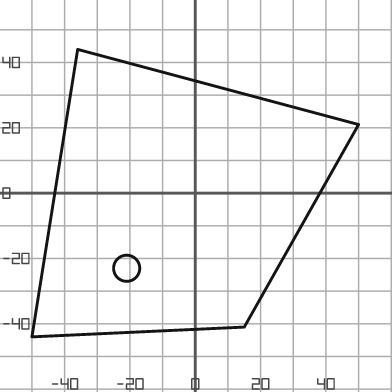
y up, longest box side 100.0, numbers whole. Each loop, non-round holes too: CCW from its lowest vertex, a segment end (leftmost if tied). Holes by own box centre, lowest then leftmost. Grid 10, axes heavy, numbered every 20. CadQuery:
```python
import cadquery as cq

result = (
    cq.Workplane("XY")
    .moveTo(-50.0, -44.0)
    .lineTo(15.0, -41.0)
    .lineTo(50.0, 21.0)
    .lineTo(-36.0, 44.0)
    .close()
    .moveTo(-21.0, -23.0)
    .circle(4.0)
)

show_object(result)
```